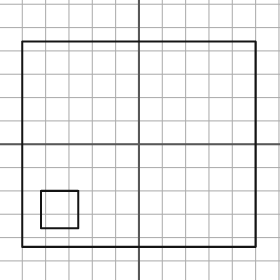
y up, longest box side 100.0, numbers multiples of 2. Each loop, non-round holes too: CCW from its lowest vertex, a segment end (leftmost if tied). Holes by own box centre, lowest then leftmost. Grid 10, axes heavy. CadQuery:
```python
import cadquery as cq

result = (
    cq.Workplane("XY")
    .moveTo(-50.0, -44.0)
    .lineTo(50.0, -44.0)
    .lineTo(50.0, 44.0)
    .lineTo(-50.0, 44.0)
    .close()
    .moveTo(-42.0, -36.0)
    .lineTo(-26.0, -36.0)
    .lineTo(-26.0, -20.0)
    .lineTo(-42.0, -20.0)
    .close()
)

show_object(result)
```